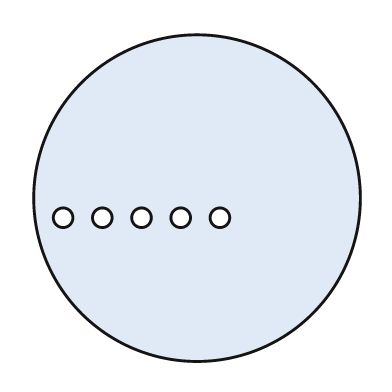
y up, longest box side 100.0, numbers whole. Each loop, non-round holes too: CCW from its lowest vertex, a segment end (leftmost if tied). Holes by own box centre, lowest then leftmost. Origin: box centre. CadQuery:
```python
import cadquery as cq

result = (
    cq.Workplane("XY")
    .moveTo(0.0, 0.0)
    .circle(50.0)
    .moveTo(-41.0, -6.0)
    .circle(3.0)
    .moveTo(-29.0, -6.0)
    .circle(3.0)
    .moveTo(-17.0, -6.0)
    .circle(3.0)
    .moveTo(-5.0, -6.0)
    .circle(3.0)
    .moveTo(7.0, -6.0)
    .circle(3.0)
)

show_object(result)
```